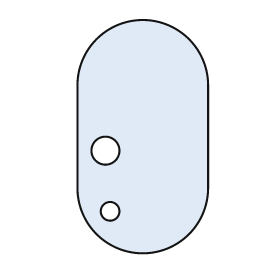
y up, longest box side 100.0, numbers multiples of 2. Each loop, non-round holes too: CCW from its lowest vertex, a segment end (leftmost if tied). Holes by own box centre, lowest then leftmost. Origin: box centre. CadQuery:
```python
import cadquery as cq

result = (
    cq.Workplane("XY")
    .moveTo(-28.0, -22.0)
    .threePointArc((0.0, -50.0), (28.0, -22.0))
    .lineTo(28.0, 22.0)
    .threePointArc((0.0, 50.0), (-28.0, 22.0))
    .close()
    .moveTo(-14.0, -32.0)
    .circle(4.0)
    .moveTo(-16.0, -6.0)
    .circle(6.0)
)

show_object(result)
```